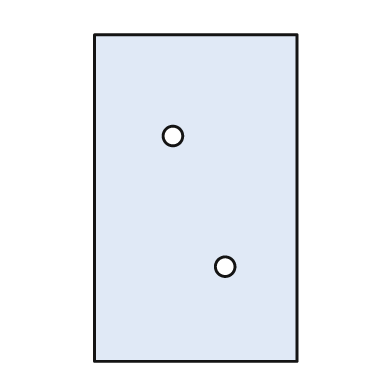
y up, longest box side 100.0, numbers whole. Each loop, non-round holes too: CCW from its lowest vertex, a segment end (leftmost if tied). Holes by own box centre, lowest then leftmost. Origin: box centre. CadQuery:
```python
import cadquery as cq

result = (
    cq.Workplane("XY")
    .moveTo(-31.0, -50.0)
    .lineTo(31.0, -50.0)
    .lineTo(31.0, 50.0)
    .lineTo(-31.0, 50.0)
    .close()
    .moveTo(9.0, -21.0)
    .circle(3.0)
    .moveTo(-7.0, 19.0)
    .circle(3.0)
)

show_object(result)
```